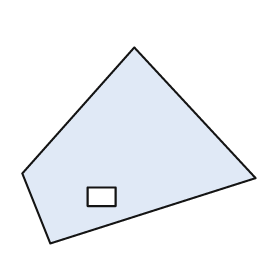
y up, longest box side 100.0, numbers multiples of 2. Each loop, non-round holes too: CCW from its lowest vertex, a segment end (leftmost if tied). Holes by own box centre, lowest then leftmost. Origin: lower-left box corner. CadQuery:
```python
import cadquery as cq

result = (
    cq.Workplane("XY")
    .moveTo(12.0, 0.0)
    .lineTo(100.0, 28.0)
    .lineTo(48.0, 84.0)
    .lineTo(0.0, 30.0)
    .close()
    .moveTo(28.0, 16.0)
    .lineTo(40.0, 16.0)
    .lineTo(40.0, 24.0)
    .lineTo(28.0, 24.0)
    .close()
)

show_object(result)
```